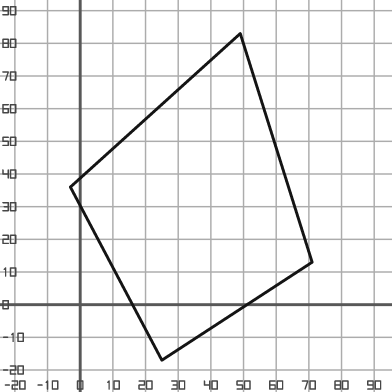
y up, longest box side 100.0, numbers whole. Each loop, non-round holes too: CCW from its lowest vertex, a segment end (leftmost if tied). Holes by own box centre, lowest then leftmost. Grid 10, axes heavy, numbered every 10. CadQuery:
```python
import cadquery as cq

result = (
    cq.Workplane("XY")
    .moveTo(25.0, -17.0)
    .lineTo(71.0, 13.0)
    .lineTo(49.0, 83.0)
    .lineTo(-3.0, 36.0)
    .close()
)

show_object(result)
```